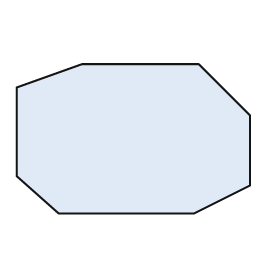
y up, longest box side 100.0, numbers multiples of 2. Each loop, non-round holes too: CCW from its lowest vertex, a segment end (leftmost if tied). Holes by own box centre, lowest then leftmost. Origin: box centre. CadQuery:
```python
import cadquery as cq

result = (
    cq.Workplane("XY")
    .moveTo(-32.0, -32.0)
    .lineTo(26.0, -32.0)
    .lineTo(50.0, -20.0)
    .lineTo(50.0, 10.0)
    .lineTo(28.0, 32.0)
    .lineTo(-22.0, 32.0)
    .lineTo(-50.0, 22.0)
    .lineTo(-50.0, -16.0)
    .close()
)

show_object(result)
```